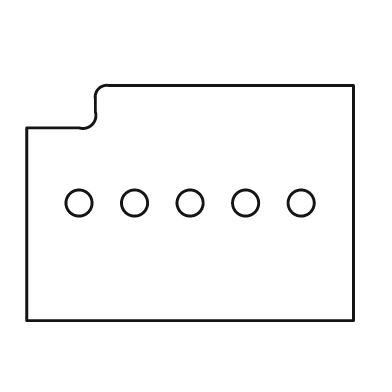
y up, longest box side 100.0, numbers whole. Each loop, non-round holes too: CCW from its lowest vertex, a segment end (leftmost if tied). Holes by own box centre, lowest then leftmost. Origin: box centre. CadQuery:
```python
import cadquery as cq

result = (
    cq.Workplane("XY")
    .moveTo(-50.0, -36.0)
    .lineTo(50.0, -36.0)
    .lineTo(50.0, 36.0)
    .lineTo(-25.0, 36.0)
    .threePointArc((-28.0, 35.0), (-29.0, 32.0))
    .lineTo(-29.0, 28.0)
    .threePointArc((-30.0, 24.0), (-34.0, 23.0))
    .lineTo(-50.0, 23.0)
    .close()
    .moveTo(-34.0, 0.0)
    .circle(4.0)
    .moveTo(-17.0, 0.0)
    .circle(4.0)
    .moveTo(0.0, 0.0)
    .circle(4.0)
    .moveTo(17.0, 0.0)
    .circle(4.0)
    .moveTo(34.0, 0.0)
    .circle(4.0)
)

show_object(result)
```